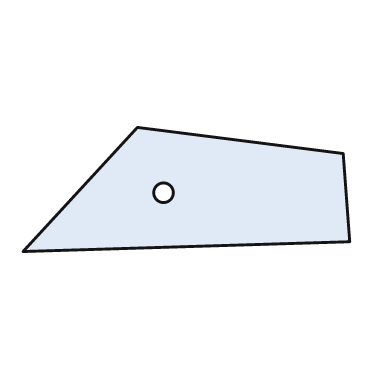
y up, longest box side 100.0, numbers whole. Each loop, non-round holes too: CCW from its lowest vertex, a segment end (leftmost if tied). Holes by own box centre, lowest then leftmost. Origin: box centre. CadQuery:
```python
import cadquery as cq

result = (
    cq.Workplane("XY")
    .moveTo(-50.0, -19.0)
    .lineTo(50.0, -16.0)
    .lineTo(48.0, 11.0)
    .lineTo(-15.0, 19.0)
    .close()
    .moveTo(-7.0, -1.0)
    .circle(3.0)
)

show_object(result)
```